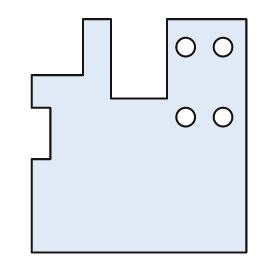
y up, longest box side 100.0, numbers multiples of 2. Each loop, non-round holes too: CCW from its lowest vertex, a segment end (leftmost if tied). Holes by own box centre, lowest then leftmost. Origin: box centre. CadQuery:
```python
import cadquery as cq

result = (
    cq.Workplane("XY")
    .moveTo(-46.0, -50.0)
    .lineTo(46.0, -50.0)
    .lineTo(46.0, 50.0)
    .lineTo(12.0, 50.0)
    .lineTo(12.0, 16.0)
    .lineTo(-12.0, 16.0)
    .lineTo(-12.0, 50.0)
    .lineTo(-24.0, 50.0)
    .lineTo(-24.0, 26.0)
    .lineTo(-46.0, 26.0)
    .lineTo(-46.0, 12.0)
    .lineTo(-38.0, 12.0)
    .lineTo(-38.0, -10.0)
    .lineTo(-46.0, -10.0)
    .close()
    .moveTo(20.0, 8.0)
    .circle(4.0)
    .moveTo(36.0, 8.0)
    .circle(4.0)
    .moveTo(20.0, 38.0)
    .circle(4.0)
    .moveTo(36.0, 38.0)
    .circle(4.0)
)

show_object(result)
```